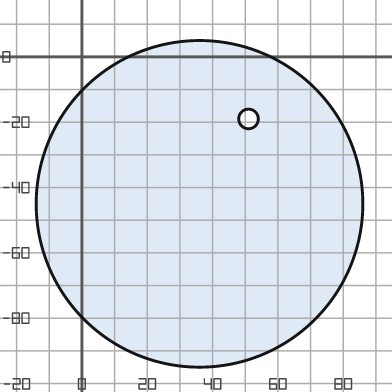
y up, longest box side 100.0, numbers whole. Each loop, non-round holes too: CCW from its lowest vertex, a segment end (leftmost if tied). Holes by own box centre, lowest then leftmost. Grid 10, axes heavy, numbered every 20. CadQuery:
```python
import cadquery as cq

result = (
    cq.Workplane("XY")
    .moveTo(36.0, -45.0)
    .circle(50.0)
    .moveTo(51.0, -19.0)
    .circle(3.0)
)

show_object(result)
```